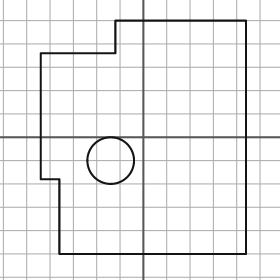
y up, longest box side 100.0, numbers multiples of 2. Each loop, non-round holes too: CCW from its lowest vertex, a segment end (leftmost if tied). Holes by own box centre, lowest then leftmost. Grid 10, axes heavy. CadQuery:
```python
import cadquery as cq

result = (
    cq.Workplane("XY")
    .moveTo(-36.0, -50.0)
    .lineTo(44.0, -50.0)
    .lineTo(44.0, 50.0)
    .lineTo(-12.0, 50.0)
    .lineTo(-12.0, 36.0)
    .lineTo(-44.0, 36.0)
    .lineTo(-44.0, -18.0)
    .lineTo(-36.0, -18.0)
    .close()
    .moveTo(-14.0, -10.0)
    .circle(10.0)
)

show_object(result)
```